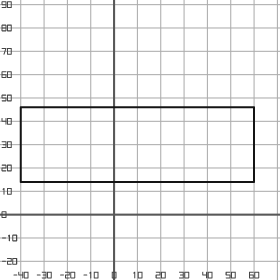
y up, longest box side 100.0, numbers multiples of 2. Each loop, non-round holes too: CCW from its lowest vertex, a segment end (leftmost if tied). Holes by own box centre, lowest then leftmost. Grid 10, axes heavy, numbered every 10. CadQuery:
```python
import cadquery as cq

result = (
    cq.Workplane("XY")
    .moveTo(-40.0, 14.0)
    .lineTo(60.0, 14.0)
    .lineTo(60.0, 46.0)
    .lineTo(-40.0, 46.0)
    .close()
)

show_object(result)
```